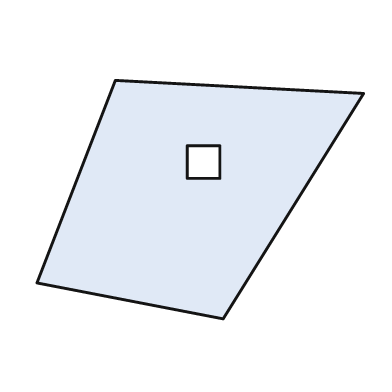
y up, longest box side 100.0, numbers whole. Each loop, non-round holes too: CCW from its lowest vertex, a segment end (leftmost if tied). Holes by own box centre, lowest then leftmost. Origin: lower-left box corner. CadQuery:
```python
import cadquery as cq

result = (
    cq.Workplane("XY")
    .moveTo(57.0, 0.0)
    .lineTo(100.0, 69.0)
    .lineTo(24.0, 73.0)
    .lineTo(0.0, 11.0)
    .close()
    .moveTo(46.0, 43.0)
    .lineTo(56.0, 43.0)
    .lineTo(56.0, 53.0)
    .lineTo(46.0, 53.0)
    .close()
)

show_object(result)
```